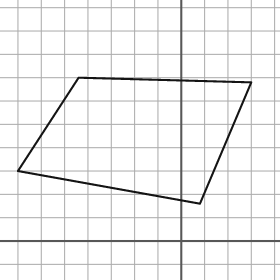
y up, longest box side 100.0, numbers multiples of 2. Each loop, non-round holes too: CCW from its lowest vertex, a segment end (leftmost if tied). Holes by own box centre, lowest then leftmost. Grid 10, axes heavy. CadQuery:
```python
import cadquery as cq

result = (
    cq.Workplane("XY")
    .moveTo(8.0, 16.0)
    .lineTo(30.0, 68.0)
    .lineTo(-44.0, 70.0)
    .lineTo(-70.0, 30.0)
    .close()
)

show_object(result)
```